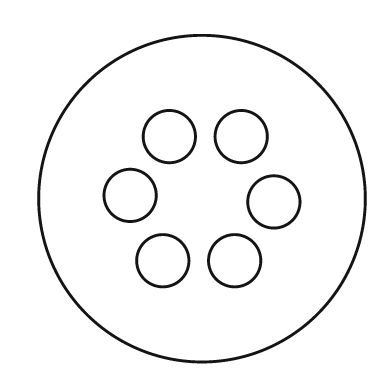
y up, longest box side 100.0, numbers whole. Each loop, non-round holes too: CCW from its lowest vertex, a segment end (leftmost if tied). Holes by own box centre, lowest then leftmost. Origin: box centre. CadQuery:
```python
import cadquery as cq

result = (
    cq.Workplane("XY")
    .moveTo(0.0, 0.0)
    .circle(50.0)
    .moveTo(-12.0, -19.0)
    .circle(8.0)
    .moveTo(10.0, -19.0)
    .circle(8.0)
    .moveTo(22.0, -1.0)
    .circle(8.0)
    .moveTo(-22.0, 1.0)
    .circle(8.0)
    .moveTo(-10.0, 19.0)
    .circle(8.0)
    .moveTo(12.0, 19.0)
    .circle(8.0)
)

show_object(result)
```